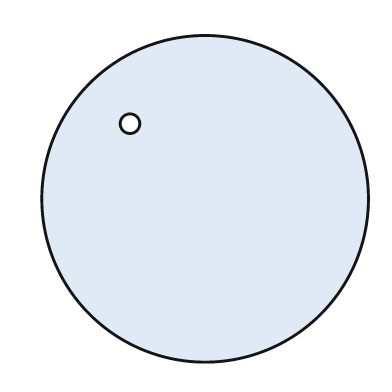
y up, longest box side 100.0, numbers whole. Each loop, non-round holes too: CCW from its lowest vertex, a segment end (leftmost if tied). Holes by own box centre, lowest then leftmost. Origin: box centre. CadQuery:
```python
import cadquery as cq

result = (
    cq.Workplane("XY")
    .moveTo(0.0, 0.0)
    .circle(50.0)
    .moveTo(-23.0, 23.0)
    .circle(3.0)
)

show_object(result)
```